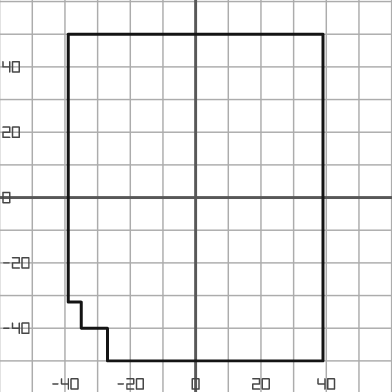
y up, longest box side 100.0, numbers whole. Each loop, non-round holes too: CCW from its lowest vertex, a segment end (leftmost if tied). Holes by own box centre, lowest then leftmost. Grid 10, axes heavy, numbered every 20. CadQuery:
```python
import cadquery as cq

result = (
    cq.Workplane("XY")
    .moveTo(-27.0, -50.0)
    .lineTo(39.0, -50.0)
    .lineTo(39.0, 50.0)
    .lineTo(-39.0, 50.0)
    .lineTo(-39.0, -32.0)
    .lineTo(-35.0, -32.0)
    .lineTo(-35.0, -40.0)
    .lineTo(-27.0, -40.0)
    .close()
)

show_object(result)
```